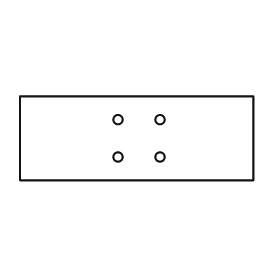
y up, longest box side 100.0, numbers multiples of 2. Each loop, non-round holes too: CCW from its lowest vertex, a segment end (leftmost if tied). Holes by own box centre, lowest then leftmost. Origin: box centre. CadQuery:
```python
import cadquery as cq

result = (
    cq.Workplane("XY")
    .moveTo(-50.0, -18.0)
    .lineTo(50.0, -18.0)
    .lineTo(50.0, 18.0)
    .lineTo(-50.0, 18.0)
    .close()
    .moveTo(-8.0, -8.0)
    .circle(2.0)
    .moveTo(10.0, -8.0)
    .circle(2.0)
    .moveTo(-8.0, 8.0)
    .circle(2.0)
    .moveTo(10.0, 8.0)
    .circle(2.0)
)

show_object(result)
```